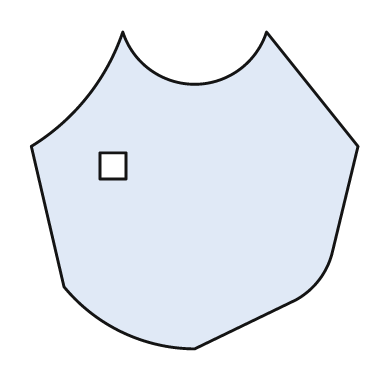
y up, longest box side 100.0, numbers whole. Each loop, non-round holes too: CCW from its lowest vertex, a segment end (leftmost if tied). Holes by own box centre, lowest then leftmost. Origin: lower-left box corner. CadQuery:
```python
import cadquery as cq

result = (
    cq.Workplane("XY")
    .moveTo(50.0, 0.0)
    .lineTo(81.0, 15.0)
    .threePointArc((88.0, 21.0), (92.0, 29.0))
    .lineTo(100.0, 62.0)
    .lineTo(72.0, 97.0)
    .threePointArc((50.0, 81.0), (28.0, 97.0))
    .threePointArc((17.0, 77.0), (0.0, 62.0))
    .lineTo(10.0, 19.0)
    .threePointArc((28.0, 5.0), (50.0, 0.0))
    .close()
    .moveTo(21.0, 52.0)
    .lineTo(29.0, 52.0)
    .lineTo(29.0, 60.0)
    .lineTo(21.0, 60.0)
    .close()
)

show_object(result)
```